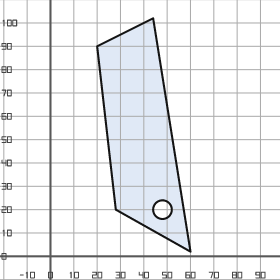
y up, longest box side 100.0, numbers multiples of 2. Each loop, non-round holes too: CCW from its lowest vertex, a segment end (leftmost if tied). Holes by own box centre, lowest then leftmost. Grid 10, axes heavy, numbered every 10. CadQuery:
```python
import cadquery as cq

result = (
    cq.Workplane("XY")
    .moveTo(60.0, 2.0)
    .lineTo(44.0, 102.0)
    .lineTo(20.0, 90.0)
    .lineTo(28.0, 20.0)
    .close()
    .moveTo(48.0, 20.0)
    .circle(4.0)
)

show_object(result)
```